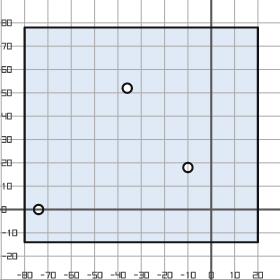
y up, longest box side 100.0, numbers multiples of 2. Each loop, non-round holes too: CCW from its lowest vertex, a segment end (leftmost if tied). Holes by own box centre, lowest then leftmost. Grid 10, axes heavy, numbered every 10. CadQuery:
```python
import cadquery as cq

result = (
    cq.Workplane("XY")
    .moveTo(-80.0, -14.0)
    .lineTo(20.0, -14.0)
    .lineTo(20.0, 78.0)
    .lineTo(-80.0, 78.0)
    .close()
    .moveTo(-74.0, 0.0)
    .circle(2.0)
    .moveTo(-10.0, 18.0)
    .circle(2.0)
    .moveTo(-36.0, 52.0)
    .circle(2.0)
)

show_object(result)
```